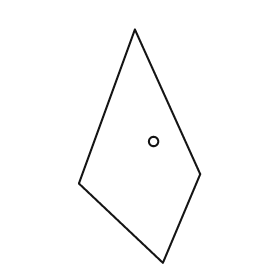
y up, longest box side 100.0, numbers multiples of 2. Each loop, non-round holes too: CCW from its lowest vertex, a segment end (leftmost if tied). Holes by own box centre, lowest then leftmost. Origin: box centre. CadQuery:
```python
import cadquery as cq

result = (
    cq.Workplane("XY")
    .moveTo(10.0, -50.0)
    .lineTo(26.0, -12.0)
    .lineTo(-2.0, 50.0)
    .lineTo(-26.0, -16.0)
    .close()
    .moveTo(6.0, 2.0)
    .circle(2.0)
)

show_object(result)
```